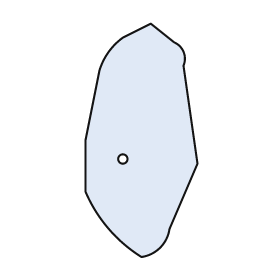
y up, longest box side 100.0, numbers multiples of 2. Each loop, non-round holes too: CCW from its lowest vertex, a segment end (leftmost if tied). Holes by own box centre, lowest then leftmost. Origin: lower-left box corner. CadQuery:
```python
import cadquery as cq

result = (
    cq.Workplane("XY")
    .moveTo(24.0, 0.0)
    .threePointArc((32.0, 4.0), (36.0, 12.0))
    .lineTo(48.0, 40.0)
    .lineTo(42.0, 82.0)
    .threePointArc((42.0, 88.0), (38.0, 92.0))
    .lineTo(28.0, 100.0)
    .lineTo(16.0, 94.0)
    .threePointArc((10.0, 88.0), (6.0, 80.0))
    .lineTo(0.0, 50.0)
    .lineTo(0.0, 28.0)
    .threePointArc((10.0, 12.0), (24.0, 0.0))
    .close()
    .moveTo(16.0, 42.0)
    .circle(2.0)
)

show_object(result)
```